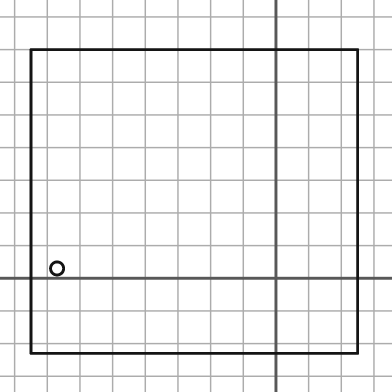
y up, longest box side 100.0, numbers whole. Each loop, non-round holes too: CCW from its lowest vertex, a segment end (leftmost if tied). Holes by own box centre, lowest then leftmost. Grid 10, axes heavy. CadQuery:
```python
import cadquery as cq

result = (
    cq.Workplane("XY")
    .moveTo(-75.0, -23.0)
    .lineTo(25.0, -23.0)
    .lineTo(25.0, 70.0)
    .lineTo(-75.0, 70.0)
    .close()
    .moveTo(-67.0, 3.0)
    .circle(2.0)
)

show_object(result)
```